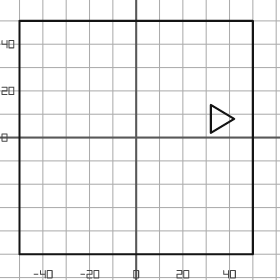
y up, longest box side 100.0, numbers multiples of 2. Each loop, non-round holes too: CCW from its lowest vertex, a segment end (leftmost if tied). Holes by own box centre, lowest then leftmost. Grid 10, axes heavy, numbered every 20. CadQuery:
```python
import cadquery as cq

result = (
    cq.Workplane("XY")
    .moveTo(-50.0, -50.0)
    .lineTo(50.0, -50.0)
    .lineTo(50.0, 50.0)
    .lineTo(-50.0, 50.0)
    .close()
    .moveTo(32.0, 2.0)
    .lineTo(42.0, 8.0)
    .lineTo(32.0, 14.0)
    .close()
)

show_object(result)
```